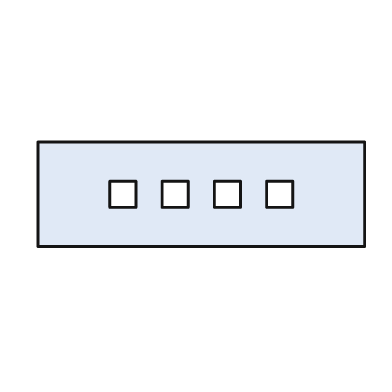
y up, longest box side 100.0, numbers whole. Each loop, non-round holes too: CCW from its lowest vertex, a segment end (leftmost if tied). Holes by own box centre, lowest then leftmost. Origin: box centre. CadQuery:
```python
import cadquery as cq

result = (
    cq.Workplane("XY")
    .moveTo(-50.0, -16.0)
    .lineTo(50.0, -16.0)
    .lineTo(50.0, 16.0)
    .lineTo(-50.0, 16.0)
    .close()
    .moveTo(-28.0, -4.0)
    .lineTo(-20.0, -4.0)
    .lineTo(-20.0, 4.0)
    .lineTo(-28.0, 4.0)
    .close()
    .moveTo(-12.0, -4.0)
    .lineTo(-4.0, -4.0)
    .lineTo(-4.0, 4.0)
    .lineTo(-12.0, 4.0)
    .close()
    .moveTo(4.0, -4.0)
    .lineTo(12.0, -4.0)
    .lineTo(12.0, 4.0)
    .lineTo(4.0, 4.0)
    .close()
    .moveTo(20.0, -4.0)
    .lineTo(28.0, -4.0)
    .lineTo(28.0, 4.0)
    .lineTo(20.0, 4.0)
    .close()
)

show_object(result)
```